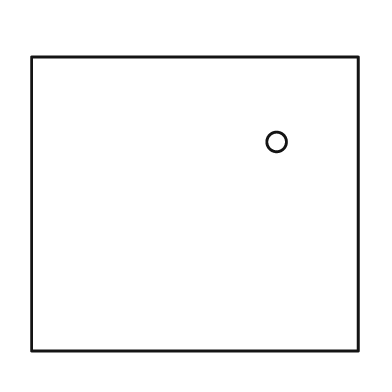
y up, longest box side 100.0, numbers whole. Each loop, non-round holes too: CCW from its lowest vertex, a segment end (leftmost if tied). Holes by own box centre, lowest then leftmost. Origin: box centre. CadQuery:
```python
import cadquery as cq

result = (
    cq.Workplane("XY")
    .moveTo(-50.0, -45.0)
    .lineTo(50.0, -45.0)
    .lineTo(50.0, 45.0)
    .lineTo(-50.0, 45.0)
    .close()
    .moveTo(25.0, 19.0)
    .circle(3.0)
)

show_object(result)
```